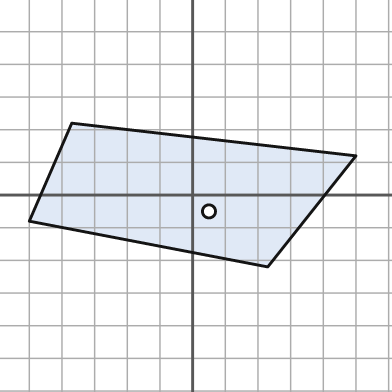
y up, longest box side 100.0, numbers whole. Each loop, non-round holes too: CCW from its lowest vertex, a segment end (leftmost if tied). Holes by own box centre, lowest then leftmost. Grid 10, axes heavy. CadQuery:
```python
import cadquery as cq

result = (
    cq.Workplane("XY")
    .moveTo(23.0, -22.0)
    .lineTo(50.0, 12.0)
    .lineTo(-37.0, 22.0)
    .lineTo(-50.0, -8.0)
    .close()
    .moveTo(5.0, -5.0)
    .circle(2.0)
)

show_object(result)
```